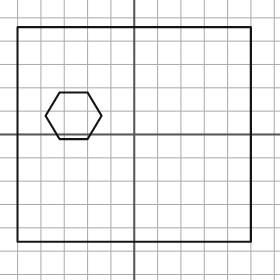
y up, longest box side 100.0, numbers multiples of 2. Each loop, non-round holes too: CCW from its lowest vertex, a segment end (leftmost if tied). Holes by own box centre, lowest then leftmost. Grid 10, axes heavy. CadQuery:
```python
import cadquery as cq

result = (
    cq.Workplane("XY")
    .moveTo(-50.0, -46.0)
    .lineTo(50.0, -46.0)
    .lineTo(50.0, 46.0)
    .lineTo(-50.0, 46.0)
    .close()
    .moveTo(-32.0, -2.0)
    .lineTo(-20.0, -2.0)
    .lineTo(-14.0, 8.0)
    .lineTo(-20.0, 18.0)
    .lineTo(-32.0, 18.0)
    .lineTo(-38.0, 8.0)
    .close()
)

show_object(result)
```